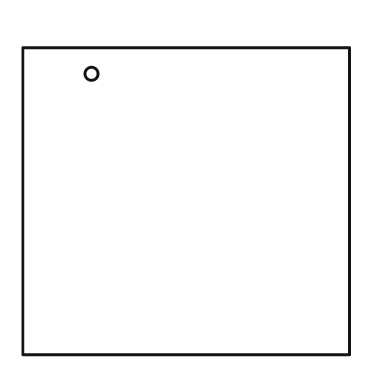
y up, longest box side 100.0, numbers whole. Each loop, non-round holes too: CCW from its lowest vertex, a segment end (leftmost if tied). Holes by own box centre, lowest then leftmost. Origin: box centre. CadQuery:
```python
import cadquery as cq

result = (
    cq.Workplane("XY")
    .moveTo(-50.0, -47.0)
    .lineTo(50.0, -47.0)
    .lineTo(50.0, 47.0)
    .lineTo(-50.0, 47.0)
    .close()
    .moveTo(-29.0, 39.0)
    .circle(2.0)
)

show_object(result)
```